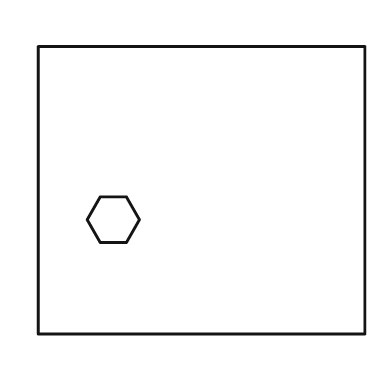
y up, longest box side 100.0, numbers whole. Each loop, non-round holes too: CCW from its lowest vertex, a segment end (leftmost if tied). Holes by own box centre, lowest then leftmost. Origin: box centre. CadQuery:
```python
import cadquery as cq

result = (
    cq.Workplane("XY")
    .moveTo(-50.0, -44.0)
    .lineTo(50.0, -44.0)
    .lineTo(50.0, 44.0)
    .lineTo(-50.0, 44.0)
    .close()
    .moveTo(-31.0, -16.0)
    .lineTo(-23.0, -16.0)
    .lineTo(-19.0, -9.0)
    .lineTo(-23.0, -2.0)
    .lineTo(-31.0, -2.0)
    .lineTo(-35.0, -9.0)
    .close()
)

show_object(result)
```